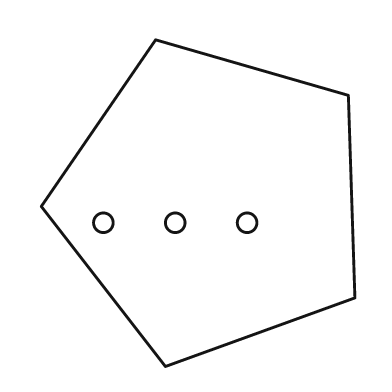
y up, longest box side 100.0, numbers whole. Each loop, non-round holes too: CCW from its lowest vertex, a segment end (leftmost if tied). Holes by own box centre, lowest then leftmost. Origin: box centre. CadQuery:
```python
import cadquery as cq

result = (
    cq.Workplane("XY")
    .moveTo(-10.0, -50.0)
    .lineTo(48.0, -29.0)
    .lineTo(46.0, 33.0)
    .lineTo(-13.0, 50.0)
    .lineTo(-48.0, -1.0)
    .close()
    .moveTo(-29.0, -6.0)
    .circle(3.0)
    .moveTo(-7.0, -6.0)
    .circle(3.0)
    .moveTo(15.0, -6.0)
    .circle(3.0)
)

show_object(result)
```